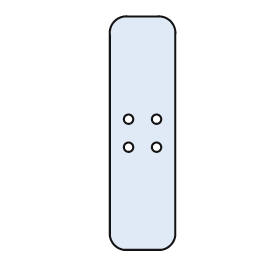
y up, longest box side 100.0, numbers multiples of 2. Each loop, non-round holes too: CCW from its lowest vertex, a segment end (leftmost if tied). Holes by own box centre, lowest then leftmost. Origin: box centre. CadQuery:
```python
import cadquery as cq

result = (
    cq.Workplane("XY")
    .moveTo(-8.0, -50.0)
    .lineTo(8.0, -50.0)
    .threePointArc((12.0, -48.0), (14.0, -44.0))
    .lineTo(14.0, 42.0)
    .threePointArc((12.0, 48.0), (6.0, 50.0))
    .lineTo(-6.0, 50.0)
    .threePointArc((-12.0, 48.0), (-14.0, 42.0))
    .lineTo(-14.0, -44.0)
    .threePointArc((-12.0, -48.0), (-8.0, -50.0))
    .close()
    .moveTo(-6.0, -6.0)
    .circle(2.0)
    .moveTo(6.0, -6.0)
    .circle(2.0)
    .moveTo(-6.0, 6.0)
    .circle(2.0)
    .moveTo(6.0, 6.0)
    .circle(2.0)
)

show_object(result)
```